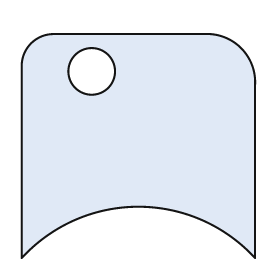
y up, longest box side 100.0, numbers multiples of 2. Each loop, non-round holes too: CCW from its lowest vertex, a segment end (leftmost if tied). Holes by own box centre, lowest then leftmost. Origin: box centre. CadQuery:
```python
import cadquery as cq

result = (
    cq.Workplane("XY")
    .moveTo(-50.0, -48.0)
    .threePointArc((0.0, -26.0), (50.0, -48.0))
    .lineTo(50.0, 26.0)
    .threePointArc((44.0, 42.0), (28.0, 48.0))
    .lineTo(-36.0, 48.0)
    .threePointArc((-46.0, 44.0), (-50.0, 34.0))
    .close()
    .moveTo(-20.0, 32.0)
    .circle(10.0)
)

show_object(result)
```